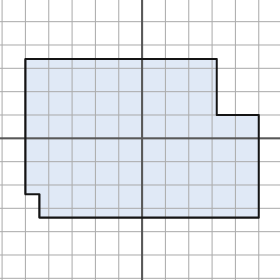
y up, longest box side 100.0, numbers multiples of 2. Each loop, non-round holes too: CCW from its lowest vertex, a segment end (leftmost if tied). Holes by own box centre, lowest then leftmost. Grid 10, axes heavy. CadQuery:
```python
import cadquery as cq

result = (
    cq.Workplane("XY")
    .moveTo(-44.0, -34.0)
    .lineTo(50.0, -34.0)
    .lineTo(50.0, 10.0)
    .lineTo(32.0, 10.0)
    .lineTo(32.0, 34.0)
    .lineTo(-50.0, 34.0)
    .lineTo(-50.0, -24.0)
    .lineTo(-44.0, -24.0)
    .close()
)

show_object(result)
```